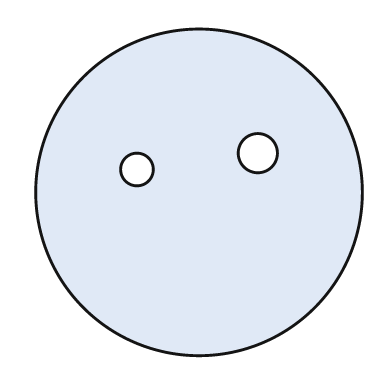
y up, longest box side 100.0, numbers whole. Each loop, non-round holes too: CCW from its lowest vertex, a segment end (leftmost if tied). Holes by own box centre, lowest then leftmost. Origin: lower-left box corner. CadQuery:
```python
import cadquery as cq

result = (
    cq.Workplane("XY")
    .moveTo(50.0, 50.0)
    .circle(50.0)
    .moveTo(31.0, 57.0)
    .circle(5.0)
    .moveTo(68.0, 62.0)
    .circle(6.0)
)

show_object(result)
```